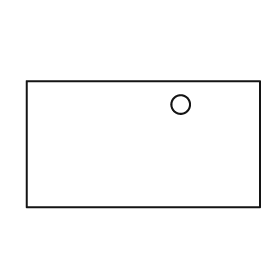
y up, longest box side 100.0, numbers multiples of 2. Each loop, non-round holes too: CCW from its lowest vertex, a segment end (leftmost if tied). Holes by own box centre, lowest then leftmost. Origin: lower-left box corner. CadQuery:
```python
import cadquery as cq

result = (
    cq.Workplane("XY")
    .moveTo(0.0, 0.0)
    .lineTo(100.0, 0.0)
    .lineTo(100.0, 54.0)
    .lineTo(0.0, 54.0)
    .close()
    .moveTo(66.0, 44.0)
    .circle(4.0)
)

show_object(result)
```